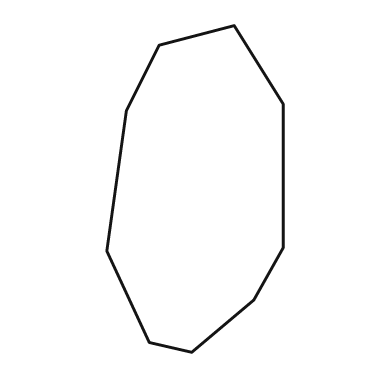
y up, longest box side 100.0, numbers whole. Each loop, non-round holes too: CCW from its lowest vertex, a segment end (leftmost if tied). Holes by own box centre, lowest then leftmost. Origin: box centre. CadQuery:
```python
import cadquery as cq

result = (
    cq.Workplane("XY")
    .moveTo(-1.0, -50.0)
    .lineTo(18.0, -34.0)
    .lineTo(27.0, -18.0)
    .lineTo(27.0, 26.0)
    .lineTo(12.0, 50.0)
    .lineTo(-11.0, 44.0)
    .lineTo(-21.0, 24.0)
    .lineTo(-27.0, -19.0)
    .lineTo(-14.0, -47.0)
    .close()
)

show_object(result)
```